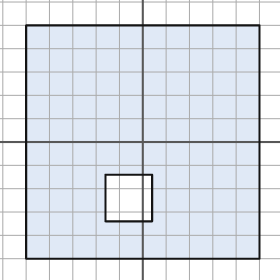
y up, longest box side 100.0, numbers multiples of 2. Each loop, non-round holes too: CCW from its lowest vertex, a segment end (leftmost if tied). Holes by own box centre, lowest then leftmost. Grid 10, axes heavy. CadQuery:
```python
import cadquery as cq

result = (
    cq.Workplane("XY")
    .moveTo(-50.0, -50.0)
    .lineTo(50.0, -50.0)
    .lineTo(50.0, 50.0)
    .lineTo(-50.0, 50.0)
    .close()
    .moveTo(-16.0, -34.0)
    .lineTo(4.0, -34.0)
    .lineTo(4.0, -14.0)
    .lineTo(-16.0, -14.0)
    .close()
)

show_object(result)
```